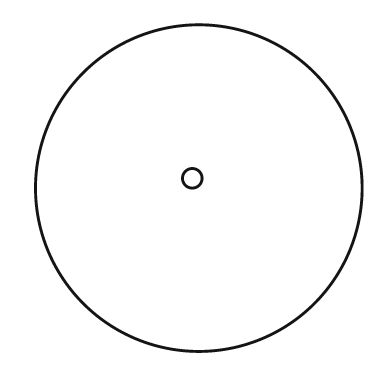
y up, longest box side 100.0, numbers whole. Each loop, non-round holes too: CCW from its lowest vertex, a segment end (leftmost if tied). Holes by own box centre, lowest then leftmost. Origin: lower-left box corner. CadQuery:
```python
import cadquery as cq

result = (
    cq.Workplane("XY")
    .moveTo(50.0, 50.0)
    .circle(50.0)
    .moveTo(48.0, 53.0)
    .circle(3.0)
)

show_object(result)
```